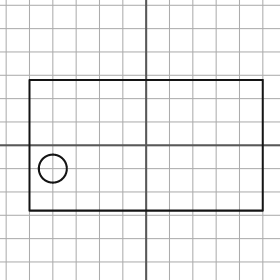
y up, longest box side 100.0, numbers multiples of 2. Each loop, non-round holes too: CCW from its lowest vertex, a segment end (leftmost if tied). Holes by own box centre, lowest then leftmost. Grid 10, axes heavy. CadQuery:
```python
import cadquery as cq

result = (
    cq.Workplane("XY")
    .moveTo(-50.0, -28.0)
    .lineTo(50.0, -28.0)
    .lineTo(50.0, 28.0)
    .lineTo(-50.0, 28.0)
    .close()
    .moveTo(-40.0, -10.0)
    .circle(6.0)
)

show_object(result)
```